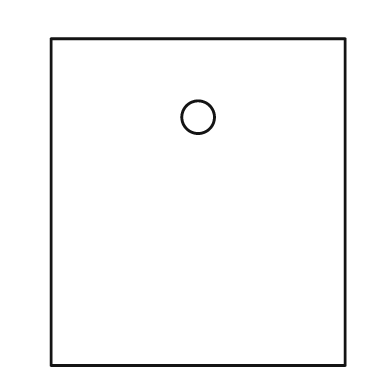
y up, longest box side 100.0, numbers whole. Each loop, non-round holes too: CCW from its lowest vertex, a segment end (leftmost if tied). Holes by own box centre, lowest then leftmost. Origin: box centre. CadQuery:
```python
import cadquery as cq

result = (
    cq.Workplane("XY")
    .moveTo(-45.0, -50.0)
    .lineTo(45.0, -50.0)
    .lineTo(45.0, 50.0)
    .lineTo(-45.0, 50.0)
    .close()
    .moveTo(0.0, 26.0)
    .circle(5.0)
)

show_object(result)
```